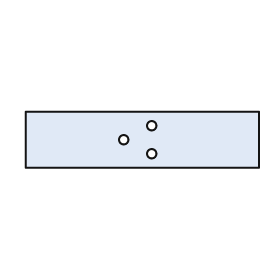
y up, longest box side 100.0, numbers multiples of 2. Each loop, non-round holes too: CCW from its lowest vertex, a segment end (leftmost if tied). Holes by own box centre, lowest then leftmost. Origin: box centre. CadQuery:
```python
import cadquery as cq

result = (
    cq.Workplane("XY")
    .moveTo(-50.0, -12.0)
    .lineTo(50.0, -12.0)
    .lineTo(50.0, 12.0)
    .lineTo(-50.0, 12.0)
    .close()
    .moveTo(4.0, -6.0)
    .circle(2.0)
    .moveTo(-8.0, 0.0)
    .circle(2.0)
    .moveTo(4.0, 6.0)
    .circle(2.0)
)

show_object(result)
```